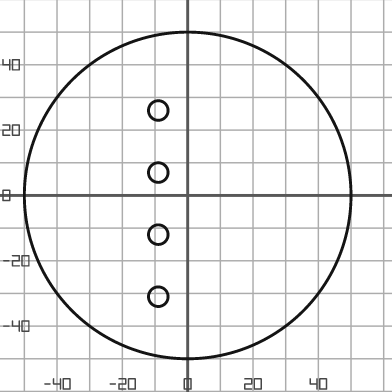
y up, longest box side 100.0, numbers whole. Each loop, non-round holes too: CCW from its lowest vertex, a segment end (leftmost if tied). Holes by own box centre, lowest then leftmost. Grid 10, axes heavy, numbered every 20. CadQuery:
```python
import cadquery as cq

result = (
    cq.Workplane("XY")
    .moveTo(0.0, 0.0)
    .circle(50.0)
    .moveTo(-9.0, -31.0)
    .circle(3.0)
    .moveTo(-9.0, -12.0)
    .circle(3.0)
    .moveTo(-9.0, 7.0)
    .circle(3.0)
    .moveTo(-9.0, 26.0)
    .circle(3.0)
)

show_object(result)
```